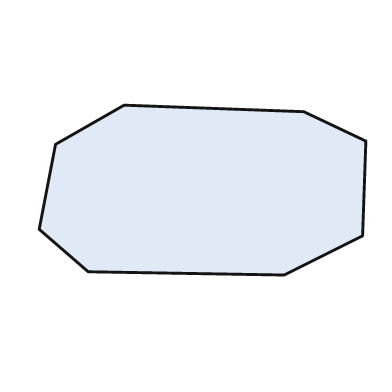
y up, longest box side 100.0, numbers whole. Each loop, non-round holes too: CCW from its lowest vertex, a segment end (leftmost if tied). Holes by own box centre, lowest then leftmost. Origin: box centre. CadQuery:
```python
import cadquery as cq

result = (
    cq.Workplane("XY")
    .moveTo(25.0, -26.0)
    .lineTo(49.0, -14.0)
    .lineTo(50.0, 15.0)
    .lineTo(31.0, 24.0)
    .lineTo(-24.0, 26.0)
    .lineTo(-45.0, 14.0)
    .lineTo(-50.0, -12.0)
    .lineTo(-35.0, -25.0)
    .close()
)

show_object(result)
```